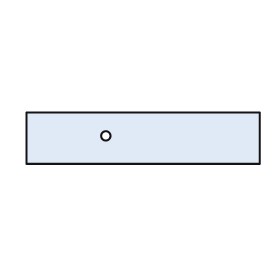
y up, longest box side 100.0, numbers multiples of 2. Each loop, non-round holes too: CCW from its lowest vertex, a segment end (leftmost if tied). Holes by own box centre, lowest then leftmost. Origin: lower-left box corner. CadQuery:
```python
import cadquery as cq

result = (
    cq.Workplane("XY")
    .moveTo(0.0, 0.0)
    .lineTo(100.0, 0.0)
    .lineTo(100.0, 22.0)
    .lineTo(0.0, 22.0)
    .close()
    .moveTo(34.0, 12.0)
    .circle(2.0)
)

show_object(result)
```